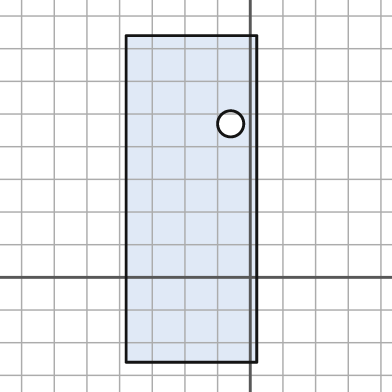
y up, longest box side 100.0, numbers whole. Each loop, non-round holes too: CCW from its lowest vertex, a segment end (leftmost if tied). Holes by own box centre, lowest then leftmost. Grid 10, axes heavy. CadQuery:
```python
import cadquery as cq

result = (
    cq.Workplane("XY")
    .moveTo(-38.0, -26.0)
    .lineTo(2.0, -26.0)
    .lineTo(2.0, 74.0)
    .lineTo(-38.0, 74.0)
    .close()
    .moveTo(-6.0, 47.0)
    .circle(4.0)
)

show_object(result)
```